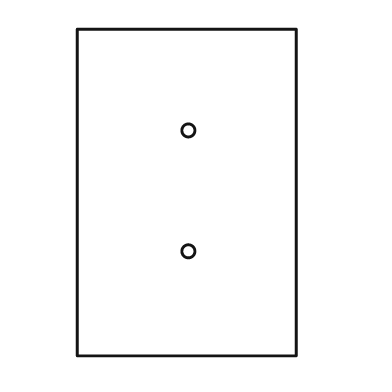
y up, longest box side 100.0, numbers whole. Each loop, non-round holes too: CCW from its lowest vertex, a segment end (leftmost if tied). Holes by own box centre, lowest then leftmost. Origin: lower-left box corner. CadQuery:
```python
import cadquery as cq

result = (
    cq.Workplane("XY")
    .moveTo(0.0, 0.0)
    .lineTo(67.0, 0.0)
    .lineTo(67.0, 100.0)
    .lineTo(0.0, 100.0)
    .close()
    .moveTo(34.0, 32.0)
    .circle(2.0)
    .moveTo(34.0, 69.0)
    .circle(2.0)
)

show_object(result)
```